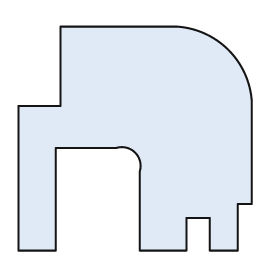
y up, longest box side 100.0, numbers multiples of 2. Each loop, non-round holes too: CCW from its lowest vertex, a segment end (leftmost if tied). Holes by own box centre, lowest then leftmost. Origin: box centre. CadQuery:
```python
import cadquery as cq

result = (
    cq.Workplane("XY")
    .moveTo(-50.0, -48.0)
    .lineTo(-34.0, -48.0)
    .lineTo(-34.0, -4.0)
    .lineTo(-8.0, -4.0)
    .threePointArc((0.0, -6.0), (2.0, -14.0))
    .lineTo(2.0, -48.0)
    .lineTo(22.0, -48.0)
    .lineTo(22.0, -34.0)
    .lineTo(32.0, -34.0)
    .lineTo(32.0, -48.0)
    .lineTo(44.0, -48.0)
    .lineTo(44.0, -28.0)
    .lineTo(50.0, -28.0)
    .lineTo(50.0, 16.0)
    .threePointArc((40.0, 38.0), (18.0, 48.0))
    .lineTo(-32.0, 48.0)
    .lineTo(-32.0, 14.0)
    .lineTo(-50.0, 14.0)
    .close()
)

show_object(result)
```